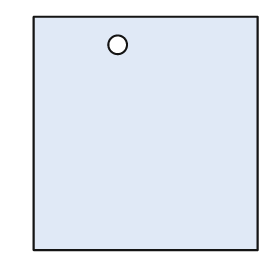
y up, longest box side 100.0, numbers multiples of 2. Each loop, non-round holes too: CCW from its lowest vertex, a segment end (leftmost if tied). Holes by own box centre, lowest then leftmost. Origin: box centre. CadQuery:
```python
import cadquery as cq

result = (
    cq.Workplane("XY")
    .moveTo(-48.0, -50.0)
    .lineTo(48.0, -50.0)
    .lineTo(48.0, 50.0)
    .lineTo(-48.0, 50.0)
    .close()
    .moveTo(-12.0, 38.0)
    .circle(4.0)
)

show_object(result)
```